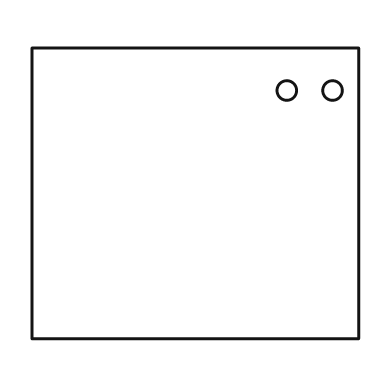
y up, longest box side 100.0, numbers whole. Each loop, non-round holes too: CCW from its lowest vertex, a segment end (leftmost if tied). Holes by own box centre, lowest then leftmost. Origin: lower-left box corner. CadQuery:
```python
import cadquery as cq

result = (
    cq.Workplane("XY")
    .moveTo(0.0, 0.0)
    .lineTo(100.0, 0.0)
    .lineTo(100.0, 89.0)
    .lineTo(0.0, 89.0)
    .close()
    .moveTo(78.0, 76.0)
    .circle(3.0)
    .moveTo(92.0, 76.0)
    .circle(3.0)
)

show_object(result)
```